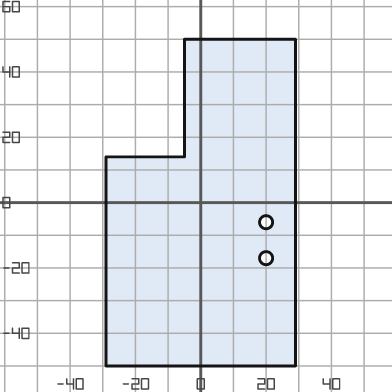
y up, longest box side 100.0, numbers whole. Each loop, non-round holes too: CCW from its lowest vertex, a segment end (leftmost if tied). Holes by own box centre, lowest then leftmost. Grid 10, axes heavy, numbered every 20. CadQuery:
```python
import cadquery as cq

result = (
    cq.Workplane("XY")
    .moveTo(-29.0, -50.0)
    .lineTo(29.0, -50.0)
    .lineTo(29.0, 50.0)
    .lineTo(-5.0, 50.0)
    .lineTo(-5.0, 14.0)
    .lineTo(-29.0, 14.0)
    .close()
    .moveTo(20.0, -17.0)
    .circle(2.0)
    .moveTo(20.0, -6.0)
    .circle(2.0)
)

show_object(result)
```